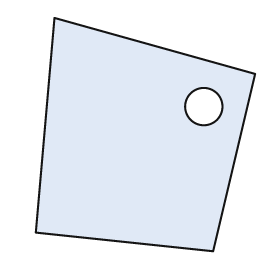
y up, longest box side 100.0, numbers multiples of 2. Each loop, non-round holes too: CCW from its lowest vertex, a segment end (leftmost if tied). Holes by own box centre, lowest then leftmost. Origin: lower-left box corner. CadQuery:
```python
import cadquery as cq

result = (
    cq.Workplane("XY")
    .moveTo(76.0, 0.0)
    .lineTo(94.0, 76.0)
    .lineTo(8.0, 100.0)
    .lineTo(0.0, 8.0)
    .close()
    .moveTo(72.0, 62.0)
    .circle(8.0)
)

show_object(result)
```